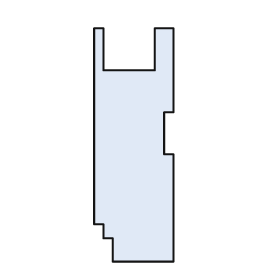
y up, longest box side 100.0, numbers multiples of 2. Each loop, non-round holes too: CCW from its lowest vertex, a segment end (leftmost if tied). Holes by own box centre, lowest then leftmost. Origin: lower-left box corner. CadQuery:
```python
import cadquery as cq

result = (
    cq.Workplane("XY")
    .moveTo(8.0, 0.0)
    .lineTo(34.0, 0.0)
    .lineTo(34.0, 46.0)
    .lineTo(30.0, 46.0)
    .lineTo(30.0, 64.0)
    .lineTo(34.0, 64.0)
    .lineTo(34.0, 100.0)
    .lineTo(26.0, 100.0)
    .lineTo(26.0, 82.0)
    .lineTo(4.0, 82.0)
    .lineTo(4.0, 100.0)
    .lineTo(0.0, 100.0)
    .lineTo(0.0, 16.0)
    .lineTo(4.0, 16.0)
    .lineTo(4.0, 10.0)
    .lineTo(8.0, 10.0)
    .close()
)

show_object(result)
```